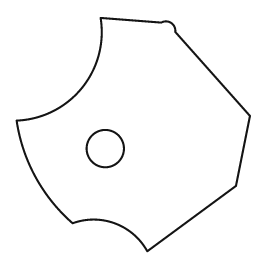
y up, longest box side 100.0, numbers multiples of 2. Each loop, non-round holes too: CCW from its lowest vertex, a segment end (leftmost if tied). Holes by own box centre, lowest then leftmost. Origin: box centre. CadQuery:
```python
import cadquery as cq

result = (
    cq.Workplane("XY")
    .moveTo(6.0, -50.0)
    .lineTo(44.0, -22.0)
    .lineTo(50.0, 8.0)
    .lineTo(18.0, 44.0)
    .threePointArc((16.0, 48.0), (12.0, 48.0))
    .lineTo(-14.0, 50.0)
    .threePointArc((-22.0, 20.0), (-50.0, 6.0))
    .threePointArc((-42.0, -18.0), (-26.0, -38.0))
    .threePointArc((-8.0, -38.0), (6.0, -50.0))
    .close()
    .moveTo(-12.0, -6.0)
    .circle(8.0)
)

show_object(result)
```